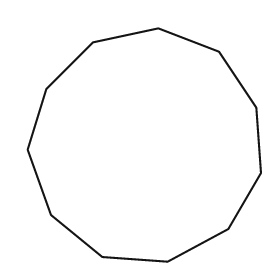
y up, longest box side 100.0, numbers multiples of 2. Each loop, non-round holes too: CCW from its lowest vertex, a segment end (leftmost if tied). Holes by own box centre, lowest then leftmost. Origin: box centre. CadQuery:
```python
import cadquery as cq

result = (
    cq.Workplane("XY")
    .moveTo(10.0, -50.0)
    .lineTo(36.0, -36.0)
    .lineTo(50.0, -12.0)
    .lineTo(48.0, 16.0)
    .lineTo(32.0, 40.0)
    .lineTo(6.0, 50.0)
    .lineTo(-22.0, 44.0)
    .lineTo(-42.0, 24.0)
    .lineTo(-50.0, -2.0)
    .lineTo(-40.0, -30.0)
    .lineTo(-18.0, -48.0)
    .close()
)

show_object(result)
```